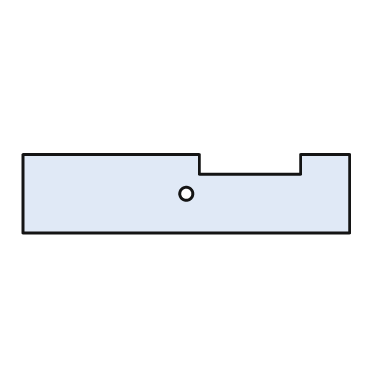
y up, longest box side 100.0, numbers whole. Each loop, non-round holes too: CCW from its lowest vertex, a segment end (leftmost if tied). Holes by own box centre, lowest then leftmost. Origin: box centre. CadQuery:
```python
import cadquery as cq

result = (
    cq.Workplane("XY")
    .moveTo(-50.0, -12.0)
    .lineTo(50.0, -12.0)
    .lineTo(50.0, 12.0)
    .lineTo(35.0, 12.0)
    .lineTo(35.0, 6.0)
    .lineTo(4.0, 6.0)
    .lineTo(4.0, 12.0)
    .lineTo(-50.0, 12.0)
    .close()
    .moveTo(0.0, 0.0)
    .circle(2.0)
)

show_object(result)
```